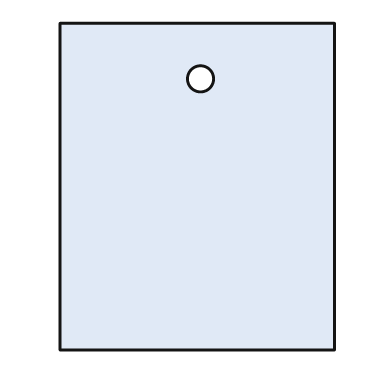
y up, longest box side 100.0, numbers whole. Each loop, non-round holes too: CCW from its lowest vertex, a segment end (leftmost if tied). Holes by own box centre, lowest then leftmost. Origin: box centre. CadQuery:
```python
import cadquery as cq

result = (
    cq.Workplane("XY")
    .moveTo(-42.0, -50.0)
    .lineTo(42.0, -50.0)
    .lineTo(42.0, 50.0)
    .lineTo(-42.0, 50.0)
    .close()
    .moveTo(1.0, 33.0)
    .circle(4.0)
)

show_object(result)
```